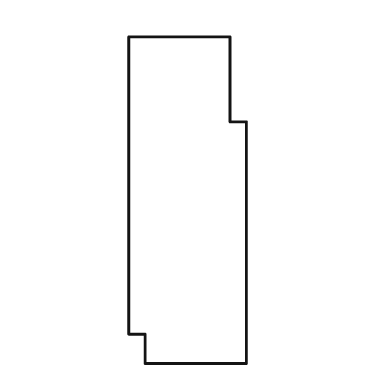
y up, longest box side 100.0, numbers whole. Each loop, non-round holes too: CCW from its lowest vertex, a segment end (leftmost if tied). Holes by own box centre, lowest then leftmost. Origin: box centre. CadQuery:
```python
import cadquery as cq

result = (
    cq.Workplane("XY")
    .moveTo(-13.0, -50.0)
    .lineTo(18.0, -50.0)
    .lineTo(18.0, 24.0)
    .lineTo(13.0, 24.0)
    .lineTo(13.0, 50.0)
    .lineTo(-18.0, 50.0)
    .lineTo(-18.0, -41.0)
    .lineTo(-13.0, -41.0)
    .close()
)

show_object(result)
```